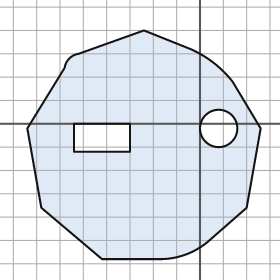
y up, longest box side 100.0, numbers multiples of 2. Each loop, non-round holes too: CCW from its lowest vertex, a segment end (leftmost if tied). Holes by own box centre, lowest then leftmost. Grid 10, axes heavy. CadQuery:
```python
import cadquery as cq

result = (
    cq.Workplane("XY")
    .moveTo(-42.0, -58.0)
    .lineTo(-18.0, -58.0)
    .threePointArc((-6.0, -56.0), (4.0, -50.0))
    .lineTo(20.0, -36.0)
    .lineTo(26.0, -2.0)
    .lineTo(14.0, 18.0)
    .threePointArc((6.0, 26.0), (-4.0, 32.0))
    .lineTo(-24.0, 40.0)
    .lineTo(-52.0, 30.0)
    .threePointArc((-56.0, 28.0), (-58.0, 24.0))
    .lineTo(-74.0, -2.0)
    .lineTo(-68.0, -36.0)
    .close()
    .moveTo(-54.0, -12.0)
    .lineTo(-30.0, -12.0)
    .lineTo(-30.0, 0.0)
    .lineTo(-54.0, 0.0)
    .close()
    .moveTo(8.0, -2.0)
    .circle(8.0)
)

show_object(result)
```